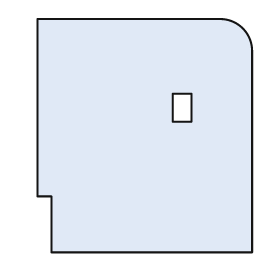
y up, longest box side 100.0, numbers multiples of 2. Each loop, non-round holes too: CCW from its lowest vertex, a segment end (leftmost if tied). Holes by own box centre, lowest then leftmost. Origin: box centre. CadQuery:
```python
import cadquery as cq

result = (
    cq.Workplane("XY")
    .moveTo(-40.0, -50.0)
    .lineTo(46.0, -50.0)
    .lineTo(46.0, 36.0)
    .threePointArc((42.0, 46.0), (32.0, 50.0))
    .lineTo(-46.0, 50.0)
    .lineTo(-46.0, -26.0)
    .lineTo(-40.0, -26.0)
    .close()
    .moveTo(12.0, 6.0)
    .lineTo(20.0, 6.0)
    .lineTo(20.0, 18.0)
    .lineTo(12.0, 18.0)
    .close()
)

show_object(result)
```